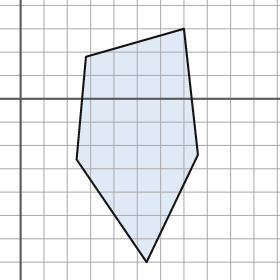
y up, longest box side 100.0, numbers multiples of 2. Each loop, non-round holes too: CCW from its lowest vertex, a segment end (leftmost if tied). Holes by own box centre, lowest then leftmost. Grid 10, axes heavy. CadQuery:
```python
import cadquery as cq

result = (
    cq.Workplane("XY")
    .moveTo(54.0, -70.0)
    .lineTo(76.0, -24.0)
    .lineTo(70.0, 30.0)
    .lineTo(28.0, 18.0)
    .lineTo(24.0, -26.0)
    .close()
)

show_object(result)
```